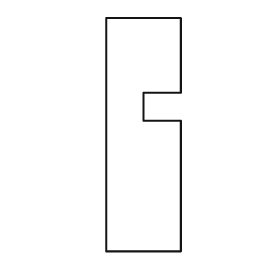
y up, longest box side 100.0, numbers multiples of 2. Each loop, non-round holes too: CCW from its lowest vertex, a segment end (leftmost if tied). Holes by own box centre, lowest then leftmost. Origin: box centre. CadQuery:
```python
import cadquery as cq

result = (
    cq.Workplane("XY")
    .moveTo(-16.0, -50.0)
    .lineTo(16.0, -50.0)
    .lineTo(16.0, 6.0)
    .lineTo(0.0, 6.0)
    .lineTo(0.0, 18.0)
    .lineTo(16.0, 18.0)
    .lineTo(16.0, 50.0)
    .lineTo(-16.0, 50.0)
    .close()
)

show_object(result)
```